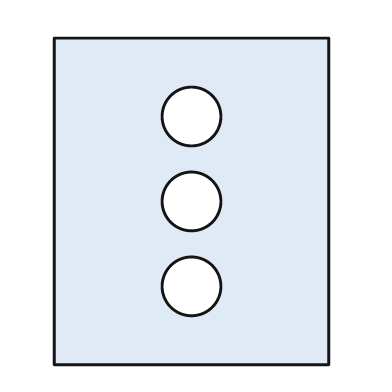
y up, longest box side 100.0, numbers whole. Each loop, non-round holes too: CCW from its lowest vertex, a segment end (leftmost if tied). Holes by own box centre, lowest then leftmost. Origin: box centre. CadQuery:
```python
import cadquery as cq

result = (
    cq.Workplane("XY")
    .moveTo(-42.0, -50.0)
    .lineTo(42.0, -50.0)
    .lineTo(42.0, 50.0)
    .lineTo(-42.0, 50.0)
    .close()
    .moveTo(0.0, -26.0)
    .circle(9.0)
    .moveTo(0.0, 0.0)
    .circle(9.0)
    .moveTo(0.0, 26.0)
    .circle(9.0)
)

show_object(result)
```